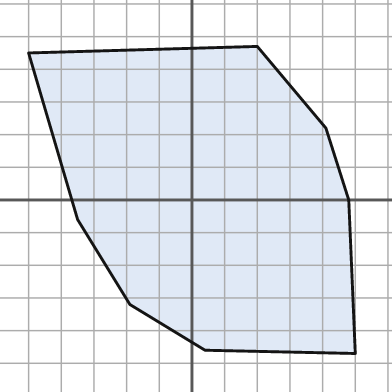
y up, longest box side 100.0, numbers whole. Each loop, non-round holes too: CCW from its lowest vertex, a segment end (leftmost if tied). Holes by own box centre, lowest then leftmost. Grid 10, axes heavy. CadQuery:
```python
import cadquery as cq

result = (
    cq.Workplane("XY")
    .moveTo(50.0, -47.0)
    .lineTo(48.0, 0.0)
    .lineTo(41.0, 22.0)
    .lineTo(20.0, 47.0)
    .lineTo(-50.0, 45.0)
    .lineTo(-35.0, -6.0)
    .lineTo(-19.0, -32.0)
    .lineTo(4.0, -46.0)
    .close()
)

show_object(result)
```